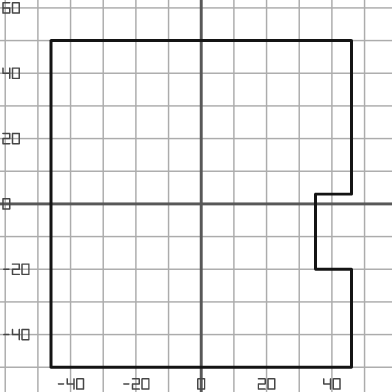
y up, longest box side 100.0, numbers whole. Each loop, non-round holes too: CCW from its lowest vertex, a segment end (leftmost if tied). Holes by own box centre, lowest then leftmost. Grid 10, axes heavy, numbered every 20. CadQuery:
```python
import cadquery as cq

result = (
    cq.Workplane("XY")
    .moveTo(-46.0, -50.0)
    .lineTo(46.0, -50.0)
    .lineTo(46.0, -20.0)
    .lineTo(35.0, -20.0)
    .lineTo(35.0, 3.0)
    .lineTo(46.0, 3.0)
    .lineTo(46.0, 50.0)
    .lineTo(-46.0, 50.0)
    .close()
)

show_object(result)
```